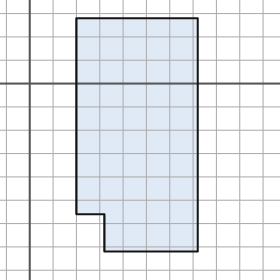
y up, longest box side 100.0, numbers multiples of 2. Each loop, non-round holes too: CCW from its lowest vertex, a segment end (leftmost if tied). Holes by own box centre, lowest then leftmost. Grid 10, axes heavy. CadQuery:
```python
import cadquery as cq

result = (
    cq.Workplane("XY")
    .moveTo(32.0, -72.0)
    .lineTo(72.0, -72.0)
    .lineTo(72.0, 28.0)
    .lineTo(20.0, 28.0)
    .lineTo(20.0, -56.0)
    .lineTo(32.0, -56.0)
    .close()
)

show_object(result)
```